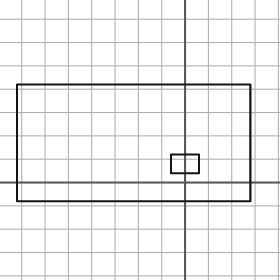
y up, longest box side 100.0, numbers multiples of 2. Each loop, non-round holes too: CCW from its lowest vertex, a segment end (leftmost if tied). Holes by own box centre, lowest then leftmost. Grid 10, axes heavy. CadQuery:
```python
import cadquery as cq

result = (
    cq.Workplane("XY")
    .moveTo(-72.0, -8.0)
    .lineTo(28.0, -8.0)
    .lineTo(28.0, 42.0)
    .lineTo(-72.0, 42.0)
    .close()
    .moveTo(-6.0, 4.0)
    .lineTo(6.0, 4.0)
    .lineTo(6.0, 12.0)
    .lineTo(-6.0, 12.0)
    .close()
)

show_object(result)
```